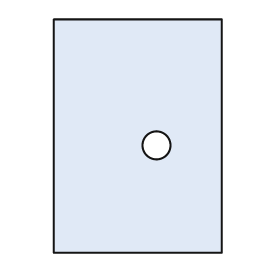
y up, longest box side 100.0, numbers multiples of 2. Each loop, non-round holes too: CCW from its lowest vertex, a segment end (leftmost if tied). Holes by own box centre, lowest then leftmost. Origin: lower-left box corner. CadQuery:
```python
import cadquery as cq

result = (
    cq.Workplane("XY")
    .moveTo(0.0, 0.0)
    .lineTo(72.0, 0.0)
    .lineTo(72.0, 100.0)
    .lineTo(0.0, 100.0)
    .close()
    .moveTo(44.0, 46.0)
    .circle(6.0)
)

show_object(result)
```